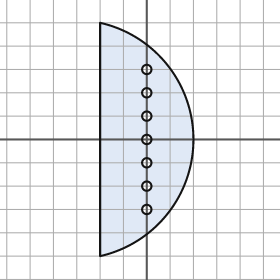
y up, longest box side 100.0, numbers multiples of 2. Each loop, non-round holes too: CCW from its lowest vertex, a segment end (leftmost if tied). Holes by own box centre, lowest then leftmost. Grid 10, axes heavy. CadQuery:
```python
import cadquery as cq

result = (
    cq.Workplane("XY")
    .moveTo(-20.0, -50.0)
    .threePointArc((20.0, 0.0), (-20.0, 50.0))
    .close()
    .moveTo(0.0, -30.0)
    .circle(2.0)
    .moveTo(0.0, -20.0)
    .circle(2.0)
    .moveTo(0.0, -10.0)
    .circle(2.0)
    .moveTo(0.0, 0.0)
    .circle(2.0)
    .moveTo(0.0, 10.0)
    .circle(2.0)
    .moveTo(0.0, 20.0)
    .circle(2.0)
    .moveTo(0.0, 30.0)
    .circle(2.0)
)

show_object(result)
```